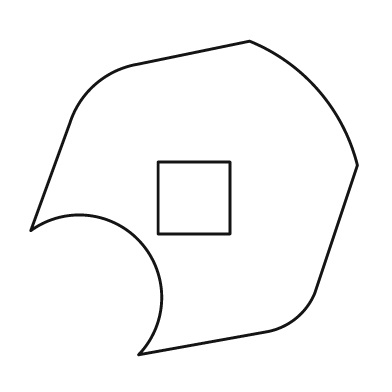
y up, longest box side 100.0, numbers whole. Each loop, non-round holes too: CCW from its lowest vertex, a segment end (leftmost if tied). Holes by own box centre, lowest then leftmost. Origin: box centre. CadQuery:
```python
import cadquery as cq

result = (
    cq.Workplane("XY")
    .moveTo(-17.0, -48.0)
    .lineTo(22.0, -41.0)
    .threePointArc((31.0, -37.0), (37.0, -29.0))
    .lineTo(50.0, 10.0)
    .threePointArc((38.0, 33.0), (17.0, 48.0))
    .lineTo(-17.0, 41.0)
    .threePointArc((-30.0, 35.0), (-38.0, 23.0))
    .lineTo(-50.0, -10.0)
    .threePointArc((-16.0, -14.0), (-17.0, -48.0))
    .close()
    .moveTo(-11.0, -11.0)
    .lineTo(11.0, -11.0)
    .lineTo(11.0, 11.0)
    .lineTo(-11.0, 11.0)
    .close()
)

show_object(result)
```